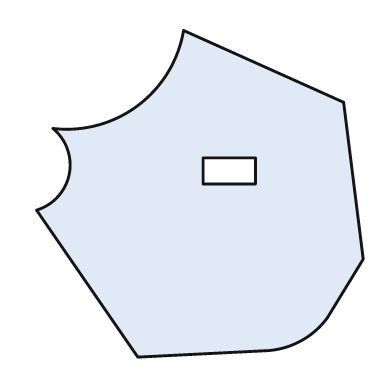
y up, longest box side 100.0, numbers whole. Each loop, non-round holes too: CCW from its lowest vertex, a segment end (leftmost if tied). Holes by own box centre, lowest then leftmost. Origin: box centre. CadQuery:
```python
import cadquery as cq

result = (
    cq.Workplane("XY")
    .moveTo(-19.0, -50.0)
    .lineTo(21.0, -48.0)
    .threePointArc((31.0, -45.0), (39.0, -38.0))
    .lineTo(50.0, -20.0)
    .lineTo(44.0, 28.0)
    .lineTo(-5.0, 50.0)
    .threePointArc((-19.0, 27.0), (-45.0, 20.0))
    .threePointArc((-40.0, 6.0), (-50.0, -5.0))
    .close()
    .moveTo(1.0, 3.0)
    .lineTo(17.0, 3.0)
    .lineTo(17.0, 11.0)
    .lineTo(1.0, 11.0)
    .close()
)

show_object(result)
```